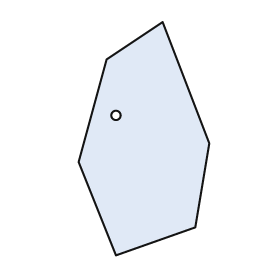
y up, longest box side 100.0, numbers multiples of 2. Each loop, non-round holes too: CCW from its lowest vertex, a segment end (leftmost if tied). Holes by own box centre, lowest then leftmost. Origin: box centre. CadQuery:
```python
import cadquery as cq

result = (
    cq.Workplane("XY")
    .moveTo(-12.0, -50.0)
    .lineTo(22.0, -38.0)
    .lineTo(28.0, -2.0)
    .lineTo(8.0, 50.0)
    .lineTo(-16.0, 34.0)
    .lineTo(-28.0, -10.0)
    .close()
    .moveTo(-12.0, 10.0)
    .circle(2.0)
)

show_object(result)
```